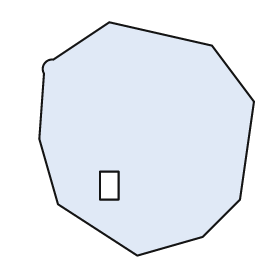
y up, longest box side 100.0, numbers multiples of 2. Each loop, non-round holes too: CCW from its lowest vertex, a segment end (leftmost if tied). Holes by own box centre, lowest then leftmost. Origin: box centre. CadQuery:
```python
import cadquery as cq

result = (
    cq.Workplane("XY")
    .moveTo(-4.0, -50.0)
    .lineTo(24.0, -42.0)
    .lineTo(40.0, -26.0)
    .lineTo(46.0, 16.0)
    .lineTo(28.0, 40.0)
    .lineTo(-16.0, 50.0)
    .lineTo(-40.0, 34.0)
    .threePointArc((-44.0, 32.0), (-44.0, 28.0))
    .lineTo(-46.0, 0.0)
    .lineTo(-38.0, -28.0)
    .close()
    .moveTo(-20.0, -26.0)
    .lineTo(-12.0, -26.0)
    .lineTo(-12.0, -14.0)
    .lineTo(-20.0, -14.0)
    .close()
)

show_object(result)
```